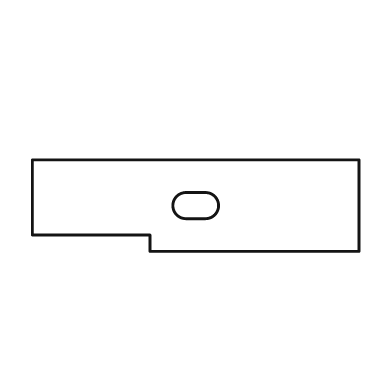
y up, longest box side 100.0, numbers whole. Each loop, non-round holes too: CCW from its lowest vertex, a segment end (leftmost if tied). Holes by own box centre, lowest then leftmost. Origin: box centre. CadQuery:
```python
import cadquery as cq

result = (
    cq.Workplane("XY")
    .moveTo(-14.0, -14.0)
    .lineTo(50.0, -14.0)
    .lineTo(50.0, 14.0)
    .lineTo(-50.0, 14.0)
    .lineTo(-50.0, -9.0)
    .lineTo(-14.0, -9.0)
    .close()
    .moveTo(-3.0, -4.0)
    .lineTo(3.0, -4.0)
    .threePointArc((7.0, 0.0), (3.0, 4.0))
    .lineTo(-3.0, 4.0)
    .threePointArc((-7.0, 0.0), (-3.0, -4.0))
    .close()
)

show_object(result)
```